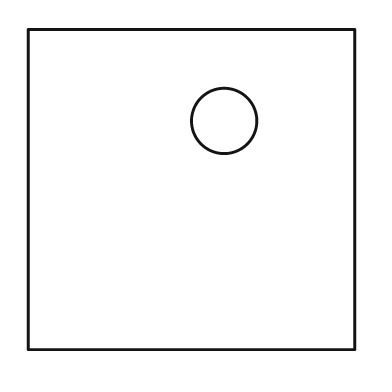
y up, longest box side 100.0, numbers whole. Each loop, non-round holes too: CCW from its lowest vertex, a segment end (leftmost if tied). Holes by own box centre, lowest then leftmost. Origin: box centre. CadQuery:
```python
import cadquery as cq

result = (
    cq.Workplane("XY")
    .moveTo(-50.0, -49.0)
    .lineTo(50.0, -49.0)
    .lineTo(50.0, 49.0)
    .lineTo(-50.0, 49.0)
    .close()
    .moveTo(10.0, 21.0)
    .circle(10.0)
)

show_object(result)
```